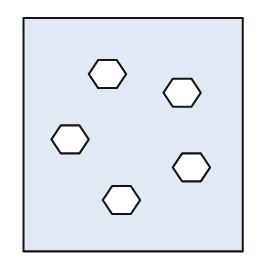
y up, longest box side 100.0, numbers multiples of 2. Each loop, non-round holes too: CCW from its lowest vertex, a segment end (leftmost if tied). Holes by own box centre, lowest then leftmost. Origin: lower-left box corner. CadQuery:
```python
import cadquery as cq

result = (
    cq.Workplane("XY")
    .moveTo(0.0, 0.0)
    .lineTo(94.0, 0.0)
    .lineTo(94.0, 100.0)
    .lineTo(0.0, 100.0)
    .close()
    .moveTo(38.0, 16.0)
    .lineTo(46.0, 16.0)
    .lineTo(50.0, 22.0)
    .lineTo(46.0, 28.0)
    .lineTo(38.0, 28.0)
    .lineTo(34.0, 22.0)
    .close()
    .moveTo(68.0, 30.0)
    .lineTo(76.0, 30.0)
    .lineTo(80.0, 36.0)
    .lineTo(76.0, 42.0)
    .lineTo(68.0, 42.0)
    .lineTo(64.0, 36.0)
    .close()
    .moveTo(16.0, 42.0)
    .lineTo(24.0, 42.0)
    .lineTo(28.0, 48.0)
    .lineTo(24.0, 54.0)
    .lineTo(16.0, 54.0)
    .lineTo(12.0, 48.0)
    .close()
    .moveTo(64.0, 62.0)
    .lineTo(72.0, 62.0)
    .lineTo(76.0, 68.0)
    .lineTo(72.0, 74.0)
    .lineTo(64.0, 74.0)
    .lineTo(60.0, 68.0)
    .close()
    .moveTo(32.0, 70.0)
    .lineTo(40.0, 70.0)
    .lineTo(44.0, 76.0)
    .lineTo(40.0, 82.0)
    .lineTo(32.0, 82.0)
    .lineTo(28.0, 76.0)
    .close()
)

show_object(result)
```